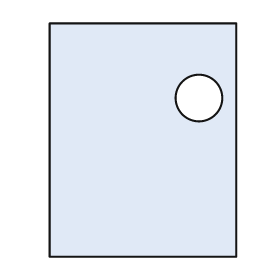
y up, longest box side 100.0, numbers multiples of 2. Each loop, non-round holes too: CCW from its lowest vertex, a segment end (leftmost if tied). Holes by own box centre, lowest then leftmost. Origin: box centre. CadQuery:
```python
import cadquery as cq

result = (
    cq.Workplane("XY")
    .moveTo(-40.0, -50.0)
    .lineTo(40.0, -50.0)
    .lineTo(40.0, 50.0)
    .lineTo(-40.0, 50.0)
    .close()
    .moveTo(24.0, 18.0)
    .circle(10.0)
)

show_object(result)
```